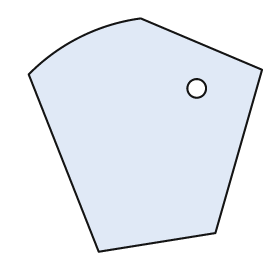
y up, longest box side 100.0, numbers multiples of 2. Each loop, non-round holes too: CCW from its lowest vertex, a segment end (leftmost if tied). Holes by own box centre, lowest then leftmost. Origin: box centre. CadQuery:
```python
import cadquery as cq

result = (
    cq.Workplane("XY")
    .moveTo(-20.0, -50.0)
    .lineTo(30.0, -42.0)
    .lineTo(50.0, 28.0)
    .lineTo(-2.0, 50.0)
    .threePointArc((-28.0, 42.0), (-50.0, 26.0))
    .close()
    .moveTo(22.0, 20.0)
    .circle(4.0)
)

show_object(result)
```